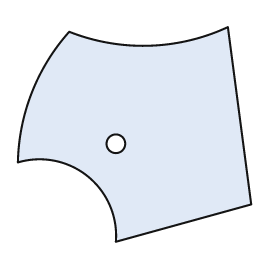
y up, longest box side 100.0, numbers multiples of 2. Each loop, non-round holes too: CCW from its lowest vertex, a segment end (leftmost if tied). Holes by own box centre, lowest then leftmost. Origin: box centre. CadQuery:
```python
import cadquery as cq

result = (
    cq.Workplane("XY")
    .moveTo(-8.0, -46.0)
    .lineTo(50.0, -30.0)
    .lineTo(40.0, 46.0)
    .threePointArc((6.0, 38.0), (-28.0, 44.0))
    .threePointArc((-44.0, 18.0), (-50.0, -12.0))
    .threePointArc((-20.0, -18.0), (-8.0, -46.0))
    .close()
    .moveTo(-8.0, -4.0)
    .circle(4.0)
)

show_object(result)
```